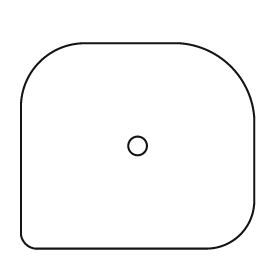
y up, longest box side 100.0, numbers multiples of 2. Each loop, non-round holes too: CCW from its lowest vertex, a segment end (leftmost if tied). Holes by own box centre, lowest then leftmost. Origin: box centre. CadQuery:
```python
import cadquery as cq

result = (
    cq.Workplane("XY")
    .moveTo(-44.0, -44.0)
    .lineTo(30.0, -44.0)
    .threePointArc((44.0, -38.0), (50.0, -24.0))
    .lineTo(50.0, 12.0)
    .threePointArc((40.0, 34.0), (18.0, 44.0))
    .lineTo(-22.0, 44.0)
    .threePointArc((-42.0, 36.0), (-50.0, 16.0))
    .lineTo(-50.0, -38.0)
    .threePointArc((-48.0, -42.0), (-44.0, -44.0))
    .close()
    .moveTo(0.0, 0.0)
    .circle(4.0)
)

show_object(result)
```